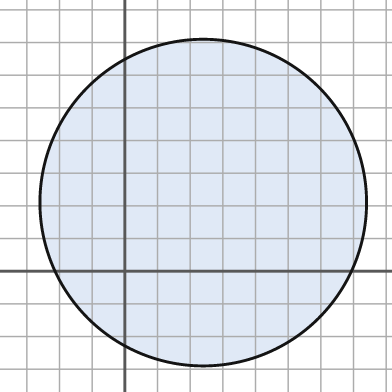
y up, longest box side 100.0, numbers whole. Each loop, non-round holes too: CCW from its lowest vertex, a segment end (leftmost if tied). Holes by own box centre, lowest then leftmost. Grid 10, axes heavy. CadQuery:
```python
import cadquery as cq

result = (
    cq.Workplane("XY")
    .moveTo(24.0, 21.0)
    .circle(50.0)
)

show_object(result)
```